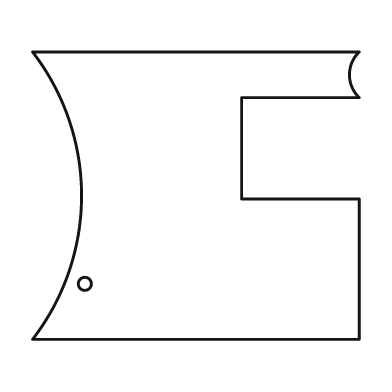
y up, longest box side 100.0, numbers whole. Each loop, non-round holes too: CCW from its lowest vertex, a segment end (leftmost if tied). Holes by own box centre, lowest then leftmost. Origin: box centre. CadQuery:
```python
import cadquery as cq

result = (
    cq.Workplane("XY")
    .moveTo(-50.0, -44.0)
    .lineTo(50.0, -44.0)
    .lineTo(50.0, -1.0)
    .lineTo(14.0, -1.0)
    .lineTo(14.0, 30.0)
    .lineTo(50.0, 30.0)
    .threePointArc((47.0, 37.0), (50.0, 44.0))
    .lineTo(-50.0, 44.0)
    .threePointArc((-35.0, 0.0), (-50.0, -44.0))
    .close()
    .moveTo(-34.0, -27.0)
    .circle(2.0)
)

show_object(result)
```